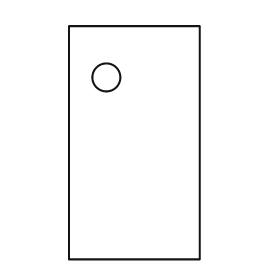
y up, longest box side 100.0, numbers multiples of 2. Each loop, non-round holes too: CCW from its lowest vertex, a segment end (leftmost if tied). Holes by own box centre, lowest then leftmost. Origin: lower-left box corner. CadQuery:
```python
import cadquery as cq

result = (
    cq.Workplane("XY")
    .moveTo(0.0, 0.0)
    .lineTo(56.0, 0.0)
    .lineTo(56.0, 100.0)
    .lineTo(0.0, 100.0)
    .close()
    .moveTo(16.0, 78.0)
    .circle(6.0)
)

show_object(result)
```